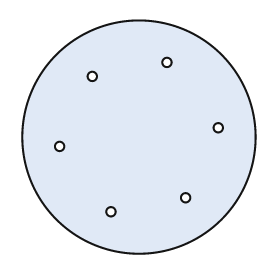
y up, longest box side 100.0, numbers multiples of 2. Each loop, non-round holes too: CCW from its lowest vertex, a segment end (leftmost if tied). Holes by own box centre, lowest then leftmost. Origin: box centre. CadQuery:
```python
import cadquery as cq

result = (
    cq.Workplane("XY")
    .moveTo(0.0, 0.0)
    .circle(50.0)
    .moveTo(-12.0, -32.0)
    .circle(2.0)
    .moveTo(20.0, -26.0)
    .circle(2.0)
    .moveTo(-34.0, -4.0)
    .circle(2.0)
    .moveTo(34.0, 4.0)
    .circle(2.0)
    .moveTo(-20.0, 26.0)
    .circle(2.0)
    .moveTo(12.0, 32.0)
    .circle(2.0)
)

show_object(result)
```